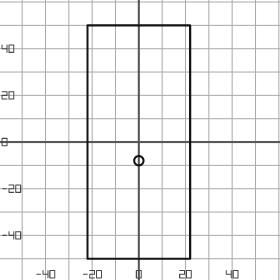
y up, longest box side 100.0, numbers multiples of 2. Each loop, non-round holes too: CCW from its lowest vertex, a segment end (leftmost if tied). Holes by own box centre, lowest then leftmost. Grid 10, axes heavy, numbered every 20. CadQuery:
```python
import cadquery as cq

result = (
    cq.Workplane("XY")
    .moveTo(-22.0, -50.0)
    .lineTo(22.0, -50.0)
    .lineTo(22.0, 50.0)
    .lineTo(-22.0, 50.0)
    .close()
    .moveTo(0.0, -8.0)
    .circle(2.0)
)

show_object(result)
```